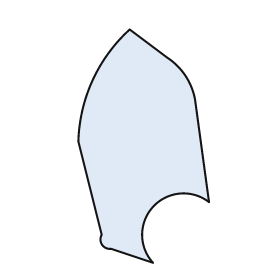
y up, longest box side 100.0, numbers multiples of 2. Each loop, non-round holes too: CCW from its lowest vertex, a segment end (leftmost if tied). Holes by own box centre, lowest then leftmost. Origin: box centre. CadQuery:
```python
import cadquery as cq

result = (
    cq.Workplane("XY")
    .moveTo(4.0, -50.0)
    .threePointArc((4.0, -26.0), (28.0, -24.0))
    .lineTo(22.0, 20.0)
    .threePointArc((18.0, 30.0), (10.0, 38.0))
    .lineTo(-6.0, 50.0)
    .threePointArc((-22.0, 28.0), (-28.0, 2.0))
    .lineTo(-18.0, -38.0)
    .threePointArc((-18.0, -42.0), (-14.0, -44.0))
    .close()
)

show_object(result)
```